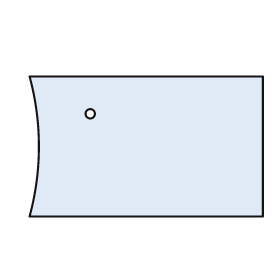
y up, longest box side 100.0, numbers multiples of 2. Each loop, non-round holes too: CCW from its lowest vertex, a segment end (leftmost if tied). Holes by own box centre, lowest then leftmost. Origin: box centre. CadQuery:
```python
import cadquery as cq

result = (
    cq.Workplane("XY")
    .moveTo(-50.0, -30.0)
    .lineTo(50.0, -30.0)
    .lineTo(50.0, 30.0)
    .lineTo(-50.0, 30.0)
    .threePointArc((-46.0, 0.0), (-50.0, -30.0))
    .close()
    .moveTo(-24.0, 14.0)
    .circle(2.0)
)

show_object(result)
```